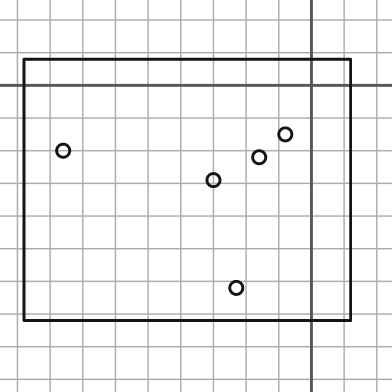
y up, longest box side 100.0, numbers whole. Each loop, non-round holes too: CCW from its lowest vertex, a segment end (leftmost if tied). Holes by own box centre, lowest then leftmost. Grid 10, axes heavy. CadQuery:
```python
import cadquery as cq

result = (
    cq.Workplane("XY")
    .moveTo(-88.0, -72.0)
    .lineTo(12.0, -72.0)
    .lineTo(12.0, 8.0)
    .lineTo(-88.0, 8.0)
    .close()
    .moveTo(-23.0, -62.0)
    .circle(2.0)
    .moveTo(-30.0, -29.0)
    .circle(2.0)
    .moveTo(-16.0, -22.0)
    .circle(2.0)
    .moveTo(-76.0, -20.0)
    .circle(2.0)
    .moveTo(-8.0, -15.0)
    .circle(2.0)
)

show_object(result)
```